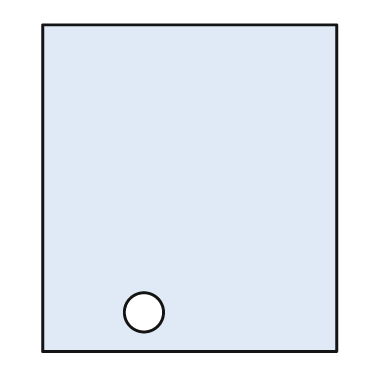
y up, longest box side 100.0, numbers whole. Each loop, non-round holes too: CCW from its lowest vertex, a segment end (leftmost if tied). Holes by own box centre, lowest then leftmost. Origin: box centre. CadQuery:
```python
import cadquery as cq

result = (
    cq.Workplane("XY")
    .moveTo(-45.0, -50.0)
    .lineTo(45.0, -50.0)
    .lineTo(45.0, 50.0)
    .lineTo(-45.0, 50.0)
    .close()
    .moveTo(-14.0, -38.0)
    .circle(6.0)
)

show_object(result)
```